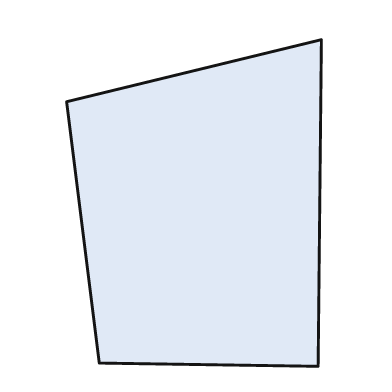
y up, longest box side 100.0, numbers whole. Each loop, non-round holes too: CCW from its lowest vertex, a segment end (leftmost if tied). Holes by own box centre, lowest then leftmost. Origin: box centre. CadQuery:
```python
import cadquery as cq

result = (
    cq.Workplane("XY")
    .moveTo(38.0, -50.0)
    .lineTo(39.0, 50.0)
    .lineTo(-39.0, 31.0)
    .lineTo(-29.0, -49.0)
    .close()
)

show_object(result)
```